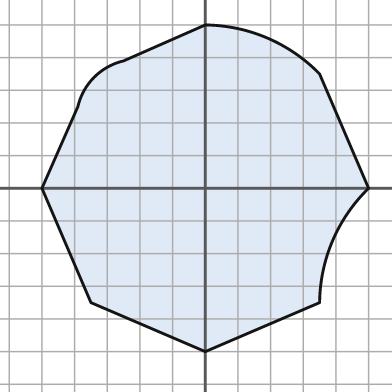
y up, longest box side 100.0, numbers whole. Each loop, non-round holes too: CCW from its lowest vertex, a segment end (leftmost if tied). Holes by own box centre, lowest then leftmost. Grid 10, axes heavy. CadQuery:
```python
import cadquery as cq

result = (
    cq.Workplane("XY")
    .moveTo(0.0, -50.0)
    .lineTo(35.0, -35.0)
    .threePointArc((39.0, -16.0), (50.0, 0.0))
    .lineTo(35.0, 35.0)
    .threePointArc((19.0, 46.0), (0.0, 50.0))
    .lineTo(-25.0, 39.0)
    .threePointArc((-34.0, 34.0), (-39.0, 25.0))
    .lineTo(-50.0, 0.0)
    .lineTo(-35.0, -35.0)
    .close()
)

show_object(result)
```